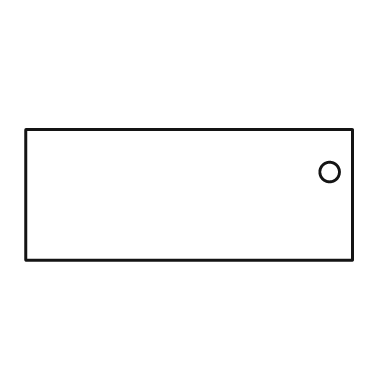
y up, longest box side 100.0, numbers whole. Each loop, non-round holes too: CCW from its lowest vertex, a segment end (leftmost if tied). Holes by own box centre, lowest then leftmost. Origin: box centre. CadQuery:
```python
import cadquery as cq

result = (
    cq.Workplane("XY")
    .moveTo(-50.0, -20.0)
    .lineTo(50.0, -20.0)
    .lineTo(50.0, 20.0)
    .lineTo(-50.0, 20.0)
    .close()
    .moveTo(43.0, 7.0)
    .circle(3.0)
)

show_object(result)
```